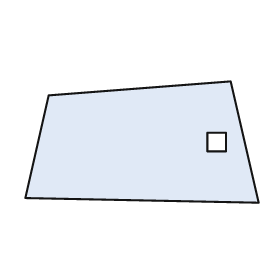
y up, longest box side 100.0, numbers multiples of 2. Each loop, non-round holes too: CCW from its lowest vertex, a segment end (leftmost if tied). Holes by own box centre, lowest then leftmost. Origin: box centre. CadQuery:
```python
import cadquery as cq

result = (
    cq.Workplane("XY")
    .moveTo(50.0, -26.0)
    .lineTo(38.0, 26.0)
    .lineTo(-40.0, 20.0)
    .lineTo(-50.0, -24.0)
    .close()
    .moveTo(28.0, -4.0)
    .lineTo(36.0, -4.0)
    .lineTo(36.0, 4.0)
    .lineTo(28.0, 4.0)
    .close()
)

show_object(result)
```